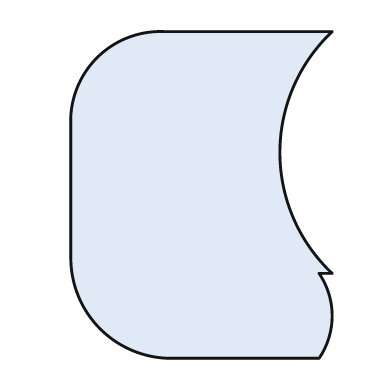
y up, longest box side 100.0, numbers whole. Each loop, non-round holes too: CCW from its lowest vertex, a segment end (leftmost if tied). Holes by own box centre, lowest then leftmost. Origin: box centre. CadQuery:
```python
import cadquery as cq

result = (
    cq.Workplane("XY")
    .moveTo(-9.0, -50.0)
    .lineTo(36.0, -50.0)
    .threePointArc((40.0, -37.0), (36.0, -24.0))
    .lineTo(40.0, -24.0)
    .threePointArc((24.0, 13.0), (40.0, 50.0))
    .lineTo(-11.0, 50.0)
    .threePointArc((-32.0, 42.0), (-40.0, 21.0))
    .lineTo(-40.0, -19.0)
    .threePointArc((-31.0, -41.0), (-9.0, -50.0))
    .close()
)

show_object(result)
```